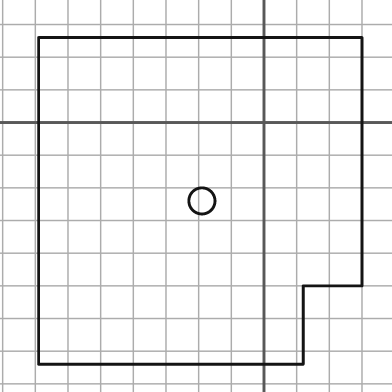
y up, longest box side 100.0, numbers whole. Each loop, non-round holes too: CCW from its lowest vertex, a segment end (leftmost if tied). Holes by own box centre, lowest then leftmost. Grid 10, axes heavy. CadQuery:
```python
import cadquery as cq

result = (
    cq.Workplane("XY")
    .moveTo(-69.0, -74.0)
    .lineTo(12.0, -74.0)
    .lineTo(12.0, -50.0)
    .lineTo(30.0, -50.0)
    .lineTo(30.0, 26.0)
    .lineTo(-69.0, 26.0)
    .close()
    .moveTo(-19.0, -24.0)
    .circle(4.0)
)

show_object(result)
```